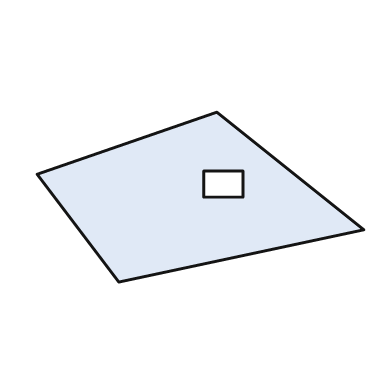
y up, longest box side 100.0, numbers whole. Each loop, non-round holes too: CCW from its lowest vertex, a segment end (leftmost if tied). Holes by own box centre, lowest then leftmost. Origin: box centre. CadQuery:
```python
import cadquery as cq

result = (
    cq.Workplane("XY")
    .moveTo(-25.0, -26.0)
    .lineTo(50.0, -10.0)
    .lineTo(5.0, 26.0)
    .lineTo(-50.0, 7.0)
    .close()
    .moveTo(1.0, 0.0)
    .lineTo(13.0, 0.0)
    .lineTo(13.0, 8.0)
    .lineTo(1.0, 8.0)
    .close()
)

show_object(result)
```